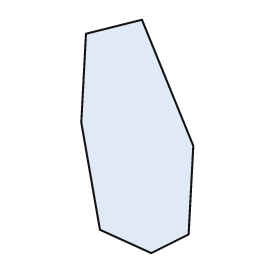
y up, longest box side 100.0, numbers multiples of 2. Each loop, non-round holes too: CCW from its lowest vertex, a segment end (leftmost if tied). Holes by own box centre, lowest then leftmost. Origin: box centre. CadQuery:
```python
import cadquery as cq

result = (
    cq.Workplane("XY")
    .moveTo(6.0, -50.0)
    .lineTo(22.0, -42.0)
    .lineTo(24.0, -4.0)
    .lineTo(2.0, 50.0)
    .lineTo(-22.0, 44.0)
    .lineTo(-24.0, 6.0)
    .lineTo(-16.0, -40.0)
    .close()
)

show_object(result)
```